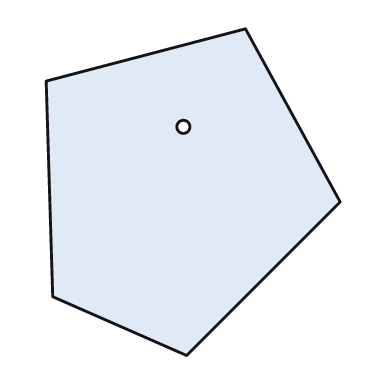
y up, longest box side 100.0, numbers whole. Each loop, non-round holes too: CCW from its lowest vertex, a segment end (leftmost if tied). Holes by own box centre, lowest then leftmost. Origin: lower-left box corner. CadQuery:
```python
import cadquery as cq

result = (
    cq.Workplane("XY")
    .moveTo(43.0, 0.0)
    .lineTo(90.0, 47.0)
    .lineTo(61.0, 100.0)
    .lineTo(0.0, 84.0)
    .lineTo(2.0, 18.0)
    .close()
    .moveTo(42.0, 70.0)
    .circle(2.0)
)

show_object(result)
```